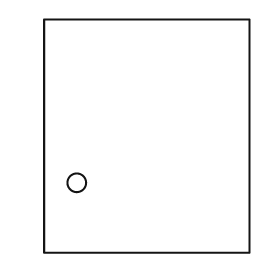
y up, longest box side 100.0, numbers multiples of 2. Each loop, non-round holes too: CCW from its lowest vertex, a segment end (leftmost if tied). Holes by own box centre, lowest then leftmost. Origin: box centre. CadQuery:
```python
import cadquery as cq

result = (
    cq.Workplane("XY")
    .moveTo(-44.0, -50.0)
    .lineTo(44.0, -50.0)
    .lineTo(44.0, 50.0)
    .lineTo(-44.0, 50.0)
    .close()
    .moveTo(-30.0, -20.0)
    .circle(4.0)
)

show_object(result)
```